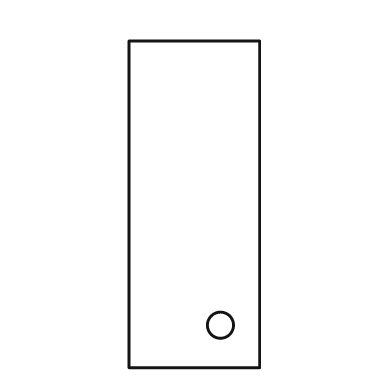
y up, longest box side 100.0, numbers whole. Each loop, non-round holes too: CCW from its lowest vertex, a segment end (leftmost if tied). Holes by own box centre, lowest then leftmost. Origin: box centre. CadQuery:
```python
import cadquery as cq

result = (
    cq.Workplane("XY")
    .moveTo(-20.0, -50.0)
    .lineTo(20.0, -50.0)
    .lineTo(20.0, 50.0)
    .lineTo(-20.0, 50.0)
    .close()
    .moveTo(8.0, -37.0)
    .circle(4.0)
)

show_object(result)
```